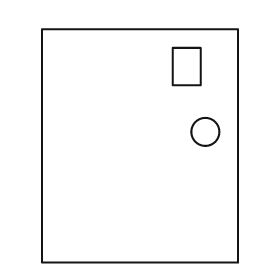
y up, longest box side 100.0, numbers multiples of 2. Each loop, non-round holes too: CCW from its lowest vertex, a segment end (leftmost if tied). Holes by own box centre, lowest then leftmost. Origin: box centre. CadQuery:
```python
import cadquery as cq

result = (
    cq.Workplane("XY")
    .moveTo(-42.0, -50.0)
    .lineTo(42.0, -50.0)
    .lineTo(42.0, 50.0)
    .lineTo(-42.0, 50.0)
    .close()
    .moveTo(28.0, 6.0)
    .circle(6.0)
    .moveTo(14.0, 26.0)
    .lineTo(26.0, 26.0)
    .lineTo(26.0, 42.0)
    .lineTo(14.0, 42.0)
    .close()
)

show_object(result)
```